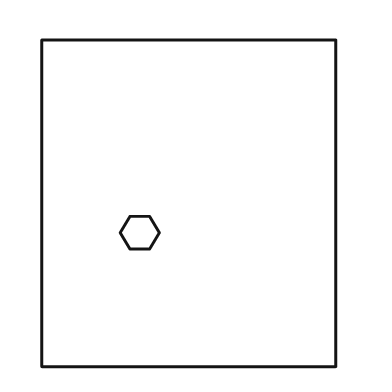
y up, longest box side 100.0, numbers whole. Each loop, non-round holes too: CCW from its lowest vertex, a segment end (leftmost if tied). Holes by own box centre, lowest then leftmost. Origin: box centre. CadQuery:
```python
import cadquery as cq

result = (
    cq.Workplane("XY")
    .moveTo(-45.0, -50.0)
    .lineTo(45.0, -50.0)
    .lineTo(45.0, 50.0)
    .lineTo(-45.0, 50.0)
    .close()
    .moveTo(-18.0, -14.0)
    .lineTo(-12.0, -14.0)
    .lineTo(-9.0, -9.0)
    .lineTo(-12.0, -4.0)
    .lineTo(-18.0, -4.0)
    .lineTo(-21.0, -9.0)
    .close()
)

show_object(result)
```